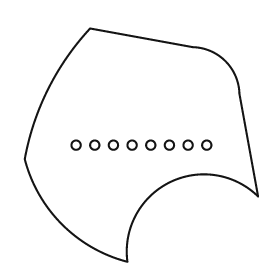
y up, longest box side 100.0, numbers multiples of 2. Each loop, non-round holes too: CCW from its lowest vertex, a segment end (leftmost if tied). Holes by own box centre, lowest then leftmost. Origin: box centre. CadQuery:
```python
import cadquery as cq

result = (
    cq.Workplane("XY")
    .moveTo(-6.0, -50.0)
    .threePointArc((12.0, -16.0), (50.0, -22.0))
    .lineTo(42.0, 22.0)
    .threePointArc((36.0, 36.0), (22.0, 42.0))
    .lineTo(-22.0, 50.0)
    .threePointArc((-40.0, 24.0), (-50.0, -6.0))
    .threePointArc((-34.0, -34.0), (-6.0, -50.0))
    .close()
    .moveTo(-28.0, 0.0)
    .circle(2.0)
    .moveTo(-20.0, 0.0)
    .circle(2.0)
    .moveTo(-12.0, 0.0)
    .circle(2.0)
    .moveTo(-4.0, 0.0)
    .circle(2.0)
    .moveTo(4.0, 0.0)
    .circle(2.0)
    .moveTo(12.0, 0.0)
    .circle(2.0)
    .moveTo(20.0, 0.0)
    .circle(2.0)
    .moveTo(28.0, 0.0)
    .circle(2.0)
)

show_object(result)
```